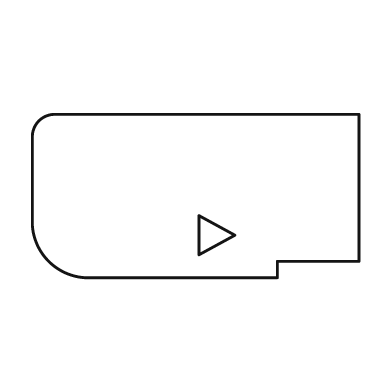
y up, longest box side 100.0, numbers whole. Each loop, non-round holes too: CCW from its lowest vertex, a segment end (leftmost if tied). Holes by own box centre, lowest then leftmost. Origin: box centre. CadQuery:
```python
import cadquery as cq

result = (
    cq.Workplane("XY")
    .moveTo(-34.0, -25.0)
    .lineTo(25.0, -25.0)
    .lineTo(25.0, -20.0)
    .lineTo(50.0, -20.0)
    .lineTo(50.0, 25.0)
    .lineTo(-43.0, 25.0)
    .threePointArc((-48.0, 23.0), (-50.0, 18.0))
    .lineTo(-50.0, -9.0)
    .threePointArc((-45.0, -20.0), (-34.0, -25.0))
    .close()
    .moveTo(1.0, -18.0)
    .lineTo(12.0, -12.0)
    .lineTo(1.0, -6.0)
    .close()
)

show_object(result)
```